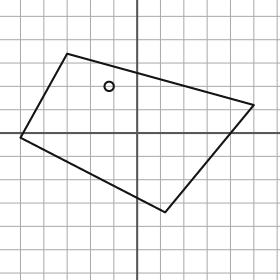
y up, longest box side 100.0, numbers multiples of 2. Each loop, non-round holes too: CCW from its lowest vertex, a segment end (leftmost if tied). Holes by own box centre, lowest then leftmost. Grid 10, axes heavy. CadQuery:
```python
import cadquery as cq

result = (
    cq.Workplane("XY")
    .moveTo(12.0, -34.0)
    .lineTo(50.0, 12.0)
    .lineTo(-30.0, 34.0)
    .lineTo(-50.0, -2.0)
    .close()
    .moveTo(-12.0, 20.0)
    .circle(2.0)
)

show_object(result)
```